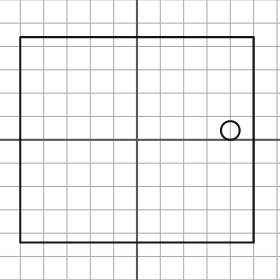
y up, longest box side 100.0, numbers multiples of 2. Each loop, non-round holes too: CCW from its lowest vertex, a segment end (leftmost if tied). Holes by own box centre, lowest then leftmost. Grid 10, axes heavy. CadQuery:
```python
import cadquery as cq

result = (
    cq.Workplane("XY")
    .moveTo(-50.0, -44.0)
    .lineTo(50.0, -44.0)
    .lineTo(50.0, 44.0)
    .lineTo(-50.0, 44.0)
    .close()
    .moveTo(40.0, 4.0)
    .circle(4.0)
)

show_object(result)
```